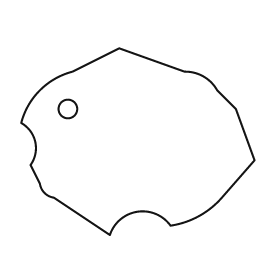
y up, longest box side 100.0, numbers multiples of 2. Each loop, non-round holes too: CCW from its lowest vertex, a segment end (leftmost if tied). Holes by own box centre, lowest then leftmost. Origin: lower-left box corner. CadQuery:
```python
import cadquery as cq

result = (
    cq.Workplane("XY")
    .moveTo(38.0, 0.0)
    .threePointArc((50.0, 10.0), (64.0, 4.0))
    .threePointArc((76.0, 8.0), (86.0, 16.0))
    .lineTo(100.0, 32.0)
    .lineTo(92.0, 54.0)
    .lineTo(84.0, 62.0)
    .threePointArc((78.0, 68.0), (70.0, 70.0))
    .lineTo(42.0, 80.0)
    .lineTo(22.0, 70.0)
    .threePointArc((8.0, 62.0), (0.0, 48.0))
    .threePointArc((6.0, 40.0), (4.0, 30.0))
    .lineTo(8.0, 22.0)
    .threePointArc((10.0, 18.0), (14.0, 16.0))
    .close()
    .moveTo(20.0, 54.0)
    .circle(4.0)
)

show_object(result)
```